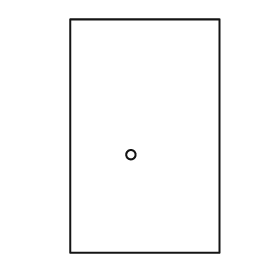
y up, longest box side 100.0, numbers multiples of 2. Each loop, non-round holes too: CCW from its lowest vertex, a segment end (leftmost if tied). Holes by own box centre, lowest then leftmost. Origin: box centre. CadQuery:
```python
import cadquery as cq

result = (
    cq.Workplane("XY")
    .moveTo(-32.0, -50.0)
    .lineTo(32.0, -50.0)
    .lineTo(32.0, 50.0)
    .lineTo(-32.0, 50.0)
    .close()
    .moveTo(-6.0, -8.0)
    .circle(2.0)
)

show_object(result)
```